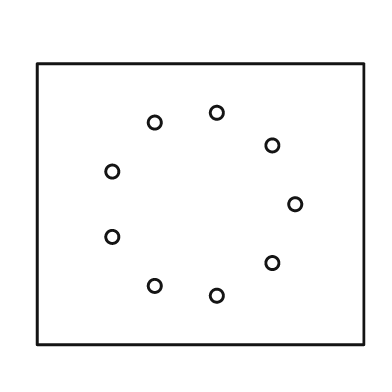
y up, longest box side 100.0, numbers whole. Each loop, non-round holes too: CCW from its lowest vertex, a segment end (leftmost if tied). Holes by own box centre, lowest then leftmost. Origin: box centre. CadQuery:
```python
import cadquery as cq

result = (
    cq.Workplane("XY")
    .moveTo(-50.0, -43.0)
    .lineTo(50.0, -43.0)
    .lineTo(50.0, 43.0)
    .lineTo(-50.0, 43.0)
    .close()
    .moveTo(5.0, -28.0)
    .circle(2.0)
    .moveTo(-14.0, -25.0)
    .circle(2.0)
    .moveTo(22.0, -18.0)
    .circle(2.0)
    .moveTo(-27.0, -10.0)
    .circle(2.0)
    .moveTo(29.0, 0.0)
    .circle(2.0)
    .moveTo(-27.0, 10.0)
    .circle(2.0)
    .moveTo(22.0, 18.0)
    .circle(2.0)
    .moveTo(-14.0, 25.0)
    .circle(2.0)
    .moveTo(5.0, 28.0)
    .circle(2.0)
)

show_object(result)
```